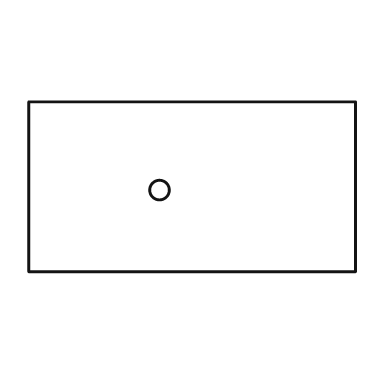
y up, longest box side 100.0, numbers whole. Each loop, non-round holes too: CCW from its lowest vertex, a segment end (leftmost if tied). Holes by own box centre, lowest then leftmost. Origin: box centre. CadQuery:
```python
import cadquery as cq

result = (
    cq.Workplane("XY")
    .moveTo(-50.0, -26.0)
    .lineTo(50.0, -26.0)
    .lineTo(50.0, 26.0)
    .lineTo(-50.0, 26.0)
    .close()
    .moveTo(-10.0, -1.0)
    .circle(3.0)
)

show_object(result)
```